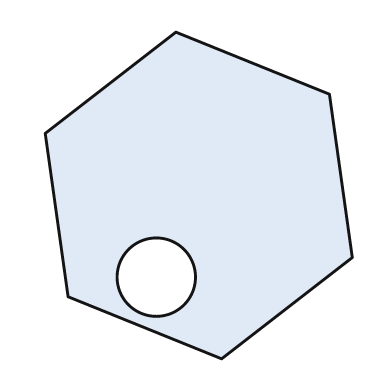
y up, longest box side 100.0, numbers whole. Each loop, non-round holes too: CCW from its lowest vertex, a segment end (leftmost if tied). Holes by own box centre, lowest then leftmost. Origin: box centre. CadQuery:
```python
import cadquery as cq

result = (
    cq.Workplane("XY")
    .moveTo(7.0, -50.0)
    .lineTo(47.0, -19.0)
    .lineTo(40.0, 31.0)
    .lineTo(-7.0, 50.0)
    .lineTo(-47.0, 19.0)
    .lineTo(-40.0, -31.0)
    .close()
    .moveTo(-13.0, -25.0)
    .circle(12.0)
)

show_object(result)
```